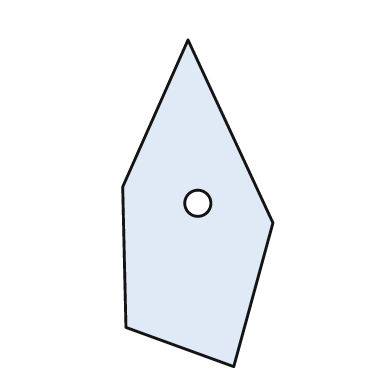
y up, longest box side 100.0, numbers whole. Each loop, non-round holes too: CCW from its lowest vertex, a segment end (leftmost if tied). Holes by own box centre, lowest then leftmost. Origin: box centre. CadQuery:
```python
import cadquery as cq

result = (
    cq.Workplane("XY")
    .moveTo(11.0, -50.0)
    .lineTo(23.0, -6.0)
    .lineTo(-3.0, 50.0)
    .lineTo(-23.0, 5.0)
    .lineTo(-22.0, -38.0)
    .close()
    .moveTo(0.0, 0.0)
    .circle(4.0)
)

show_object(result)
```